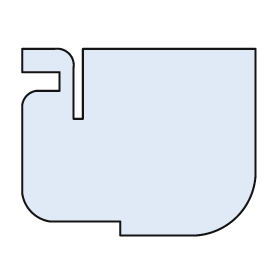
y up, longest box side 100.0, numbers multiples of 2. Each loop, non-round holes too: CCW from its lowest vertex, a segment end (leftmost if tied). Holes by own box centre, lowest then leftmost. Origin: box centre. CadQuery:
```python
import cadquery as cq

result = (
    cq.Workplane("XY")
    .moveTo(-8.0, -40.0)
    .lineTo(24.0, -40.0)
    .threePointArc((42.0, -32.0), (50.0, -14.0))
    .lineTo(50.0, 40.0)
    .lineTo(-24.0, 40.0)
    .lineTo(-24.0, 10.0)
    .lineTo(-28.0, 10.0)
    .lineTo(-28.0, 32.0)
    .threePointArc((-30.0, 38.0), (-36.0, 40.0))
    .lineTo(-50.0, 40.0)
    .lineTo(-50.0, 30.0)
    .lineTo(-34.0, 30.0)
    .lineTo(-34.0, 22.0)
    .lineTo(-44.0, 22.0)
    .threePointArc((-48.0, 20.0), (-50.0, 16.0))
    .lineTo(-50.0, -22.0)
    .threePointArc((-46.0, -30.0), (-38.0, -34.0))
    .lineTo(-8.0, -34.0)
    .close()
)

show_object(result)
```